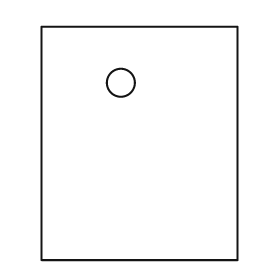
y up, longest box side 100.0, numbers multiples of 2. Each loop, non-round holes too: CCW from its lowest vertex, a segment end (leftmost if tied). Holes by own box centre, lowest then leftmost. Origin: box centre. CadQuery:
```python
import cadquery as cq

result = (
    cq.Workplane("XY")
    .moveTo(-42.0, -50.0)
    .lineTo(42.0, -50.0)
    .lineTo(42.0, 50.0)
    .lineTo(-42.0, 50.0)
    .close()
    .moveTo(-8.0, 26.0)
    .circle(6.0)
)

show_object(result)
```